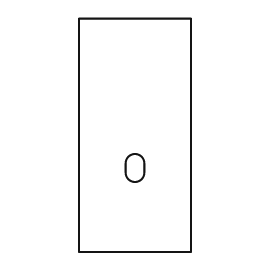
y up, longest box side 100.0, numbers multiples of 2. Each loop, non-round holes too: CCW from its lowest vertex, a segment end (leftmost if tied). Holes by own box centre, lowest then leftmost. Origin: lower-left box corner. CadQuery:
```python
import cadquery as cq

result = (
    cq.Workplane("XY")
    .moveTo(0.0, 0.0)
    .lineTo(48.0, 0.0)
    .lineTo(48.0, 100.0)
    .lineTo(0.0, 100.0)
    .close()
    .moveTo(20.0, 34.0)
    .threePointArc((24.0, 30.0), (28.0, 34.0))
    .lineTo(28.0, 38.0)
    .threePointArc((24.0, 42.0), (20.0, 38.0))
    .close()
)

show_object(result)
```